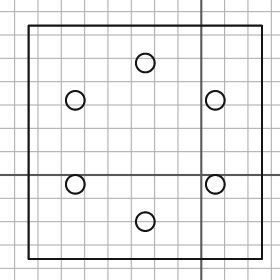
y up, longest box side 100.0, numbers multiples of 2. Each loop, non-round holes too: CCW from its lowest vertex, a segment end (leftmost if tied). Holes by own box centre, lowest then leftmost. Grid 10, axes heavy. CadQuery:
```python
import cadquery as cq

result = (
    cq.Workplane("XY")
    .moveTo(-74.0, -36.0)
    .lineTo(26.0, -36.0)
    .lineTo(26.0, 64.0)
    .lineTo(-74.0, 64.0)
    .close()
    .moveTo(-24.0, -20.0)
    .circle(4.0)
    .moveTo(-54.0, -4.0)
    .circle(4.0)
    .moveTo(6.0, -4.0)
    .circle(4.0)
    .moveTo(-54.0, 32.0)
    .circle(4.0)
    .moveTo(6.0, 32.0)
    .circle(4.0)
    .moveTo(-24.0, 48.0)
    .circle(4.0)
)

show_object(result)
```